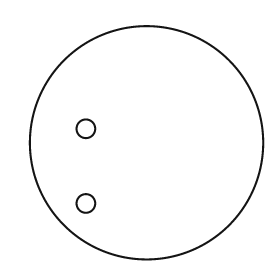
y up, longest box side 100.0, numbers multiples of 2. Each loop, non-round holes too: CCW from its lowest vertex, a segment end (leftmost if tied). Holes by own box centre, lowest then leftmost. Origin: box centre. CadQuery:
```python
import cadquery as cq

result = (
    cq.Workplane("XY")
    .moveTo(0.0, 0.0)
    .circle(50.0)
    .moveTo(-26.0, -26.0)
    .circle(4.0)
    .moveTo(-26.0, 6.0)
    .circle(4.0)
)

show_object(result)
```